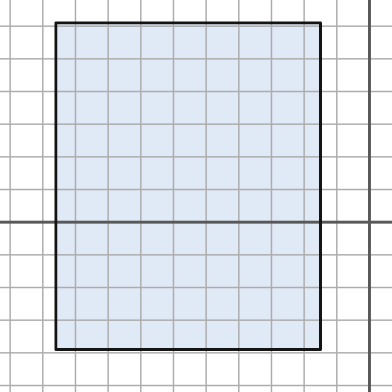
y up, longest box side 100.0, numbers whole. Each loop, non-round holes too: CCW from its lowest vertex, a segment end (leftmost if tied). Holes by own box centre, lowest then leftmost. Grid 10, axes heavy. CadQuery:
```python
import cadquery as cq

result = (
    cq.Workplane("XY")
    .moveTo(-96.0, -39.0)
    .lineTo(-15.0, -39.0)
    .lineTo(-15.0, 61.0)
    .lineTo(-96.0, 61.0)
    .close()
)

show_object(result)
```